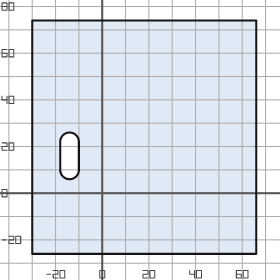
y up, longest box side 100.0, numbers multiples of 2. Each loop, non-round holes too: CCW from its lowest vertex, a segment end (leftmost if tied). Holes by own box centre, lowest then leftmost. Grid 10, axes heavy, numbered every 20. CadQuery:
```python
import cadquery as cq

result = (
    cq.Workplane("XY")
    .moveTo(-30.0, -26.0)
    .lineTo(66.0, -26.0)
    .lineTo(66.0, 74.0)
    .lineTo(-30.0, 74.0)
    .close()
    .moveTo(-18.0, 10.0)
    .threePointArc((-14.0, 6.0), (-10.0, 10.0))
    .lineTo(-10.0, 22.0)
    .threePointArc((-14.0, 26.0), (-18.0, 22.0))
    .close()
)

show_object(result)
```